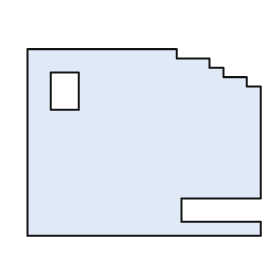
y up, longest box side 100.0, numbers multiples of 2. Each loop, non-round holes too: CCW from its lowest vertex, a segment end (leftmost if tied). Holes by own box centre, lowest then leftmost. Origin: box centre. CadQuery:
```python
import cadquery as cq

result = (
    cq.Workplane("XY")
    .moveTo(-50.0, -40.0)
    .lineTo(50.0, -40.0)
    .lineTo(50.0, -34.0)
    .lineTo(16.0, -34.0)
    .lineTo(16.0, -24.0)
    .lineTo(50.0, -24.0)
    .lineTo(50.0, 24.0)
    .lineTo(44.0, 24.0)
    .lineTo(44.0, 28.0)
    .lineTo(34.0, 28.0)
    .lineTo(34.0, 32.0)
    .lineTo(28.0, 32.0)
    .lineTo(28.0, 36.0)
    .lineTo(14.0, 36.0)
    .lineTo(14.0, 40.0)
    .lineTo(-50.0, 40.0)
    .close()
    .moveTo(-40.0, 14.0)
    .lineTo(-28.0, 14.0)
    .lineTo(-28.0, 30.0)
    .lineTo(-40.0, 30.0)
    .close()
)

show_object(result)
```